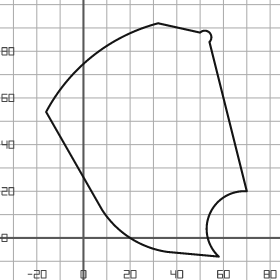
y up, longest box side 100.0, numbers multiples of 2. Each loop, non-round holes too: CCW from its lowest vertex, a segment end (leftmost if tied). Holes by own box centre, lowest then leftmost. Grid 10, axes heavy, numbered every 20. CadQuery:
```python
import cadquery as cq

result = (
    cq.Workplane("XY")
    .moveTo(58.0, -8.0)
    .threePointArc((54.0, 10.0), (70.0, 20.0))
    .lineTo(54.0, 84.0)
    .threePointArc((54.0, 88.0), (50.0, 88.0))
    .lineTo(32.0, 92.0)
    .threePointArc((4.0, 78.0), (-16.0, 54.0))
    .lineTo(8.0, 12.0)
    .threePointArc((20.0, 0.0), (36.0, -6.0))
    .close()
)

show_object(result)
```